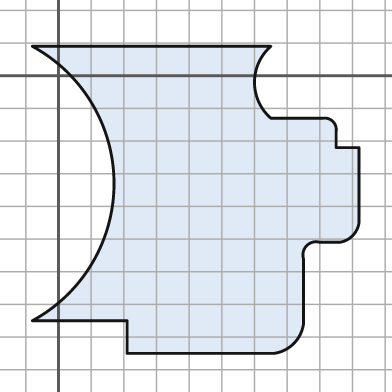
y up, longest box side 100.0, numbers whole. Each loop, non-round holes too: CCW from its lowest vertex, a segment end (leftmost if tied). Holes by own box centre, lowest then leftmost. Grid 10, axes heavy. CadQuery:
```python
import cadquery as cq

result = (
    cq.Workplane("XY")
    .moveTo(21.0, -85.0)
    .lineTo(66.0, -85.0)
    .threePointArc((72.0, -82.0), (75.0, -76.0))
    .lineTo(75.0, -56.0)
    .threePointArc((76.0, -52.0), (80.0, -51.0))
    .lineTo(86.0, -51.0)
    .threePointArc((90.0, -49.0), (92.0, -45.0))
    .lineTo(92.0, -22.0)
    .lineTo(85.0, -22.0)
    .lineTo(85.0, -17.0)
    .threePointArc((84.0, -14.0), (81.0, -13.0))
    .lineTo(65.0, -13.0)
    .threePointArc((60.0, -2.0), (65.0, 9.0))
    .lineTo(-8.0, 9.0)
    .threePointArc((17.0, -33.0), (-8.0, -75.0))
    .lineTo(21.0, -75.0)
    .close()
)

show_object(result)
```